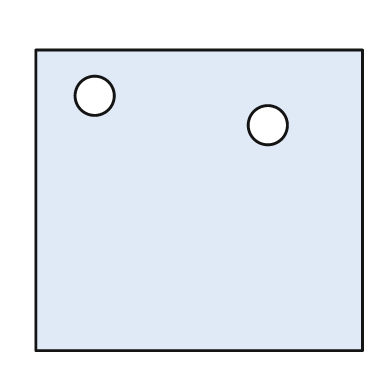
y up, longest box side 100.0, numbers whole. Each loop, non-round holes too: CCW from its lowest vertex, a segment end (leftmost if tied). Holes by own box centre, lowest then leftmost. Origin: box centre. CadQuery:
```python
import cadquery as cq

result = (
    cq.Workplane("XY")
    .moveTo(-50.0, -46.0)
    .lineTo(50.0, -46.0)
    .lineTo(50.0, 46.0)
    .lineTo(-50.0, 46.0)
    .close()
    .moveTo(21.0, 23.0)
    .circle(6.0)
    .moveTo(-32.0, 32.0)
    .circle(6.0)
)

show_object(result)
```